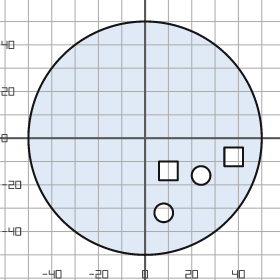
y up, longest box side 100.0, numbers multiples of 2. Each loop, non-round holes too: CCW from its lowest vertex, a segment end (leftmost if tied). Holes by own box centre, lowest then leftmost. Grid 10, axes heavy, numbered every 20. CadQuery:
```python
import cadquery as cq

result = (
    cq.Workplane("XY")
    .moveTo(0.0, 0.0)
    .circle(50.0)
    .moveTo(8.0, -32.0)
    .circle(4.0)
    .moveTo(24.0, -16.0)
    .circle(4.0)
    .moveTo(6.0, -18.0)
    .lineTo(14.0, -18.0)
    .lineTo(14.0, -10.0)
    .lineTo(6.0, -10.0)
    .close()
    .moveTo(34.0, -12.0)
    .lineTo(42.0, -12.0)
    .lineTo(42.0, -4.0)
    .lineTo(34.0, -4.0)
    .close()
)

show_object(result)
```